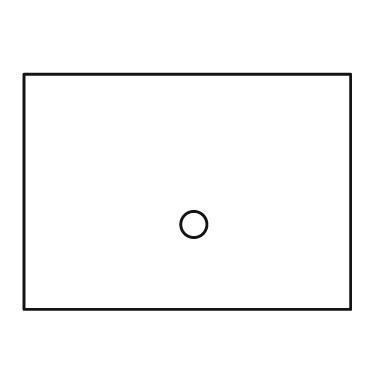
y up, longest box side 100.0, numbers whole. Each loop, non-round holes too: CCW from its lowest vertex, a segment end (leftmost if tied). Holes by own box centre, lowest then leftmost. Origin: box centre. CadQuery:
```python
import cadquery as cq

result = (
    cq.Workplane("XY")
    .moveTo(-50.0, -36.0)
    .lineTo(50.0, -36.0)
    .lineTo(50.0, 36.0)
    .lineTo(-50.0, 36.0)
    .close()
    .moveTo(2.0, -10.0)
    .circle(4.0)
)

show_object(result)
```